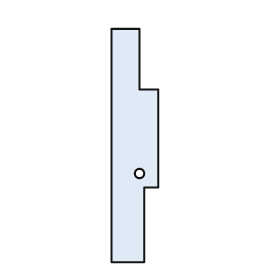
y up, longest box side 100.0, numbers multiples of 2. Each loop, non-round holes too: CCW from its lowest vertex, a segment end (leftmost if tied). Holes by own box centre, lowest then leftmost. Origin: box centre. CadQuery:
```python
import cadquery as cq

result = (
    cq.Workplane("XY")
    .moveTo(-10.0, -50.0)
    .lineTo(4.0, -50.0)
    .lineTo(4.0, -18.0)
    .lineTo(10.0, -18.0)
    .lineTo(10.0, 24.0)
    .lineTo(2.0, 24.0)
    .lineTo(2.0, 50.0)
    .lineTo(-10.0, 50.0)
    .close()
    .moveTo(2.0, -12.0)
    .circle(2.0)
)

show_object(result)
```